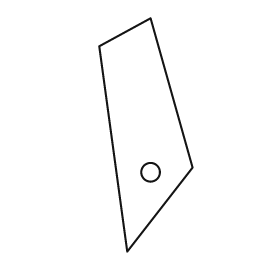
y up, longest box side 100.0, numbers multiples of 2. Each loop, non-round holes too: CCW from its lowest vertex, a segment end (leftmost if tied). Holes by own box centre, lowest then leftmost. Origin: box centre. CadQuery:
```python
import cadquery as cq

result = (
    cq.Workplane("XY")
    .moveTo(-8.0, -50.0)
    .lineTo(20.0, -14.0)
    .lineTo(2.0, 50.0)
    .lineTo(-20.0, 38.0)
    .close()
    .moveTo(2.0, -16.0)
    .circle(4.0)
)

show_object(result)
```